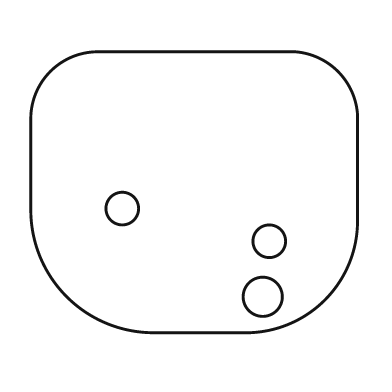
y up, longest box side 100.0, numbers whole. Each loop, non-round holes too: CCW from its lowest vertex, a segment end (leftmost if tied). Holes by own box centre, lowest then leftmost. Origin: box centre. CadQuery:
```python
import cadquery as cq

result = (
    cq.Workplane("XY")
    .moveTo(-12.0, -43.0)
    .lineTo(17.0, -43.0)
    .threePointArc((40.0, -33.0), (50.0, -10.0))
    .lineTo(50.0, 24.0)
    .threePointArc((44.0, 37.0), (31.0, 43.0))
    .lineTo(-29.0, 43.0)
    .threePointArc((-44.0, 37.0), (-50.0, 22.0))
    .lineTo(-50.0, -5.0)
    .threePointArc((-39.0, -32.0), (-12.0, -43.0))
    .close()
    .moveTo(21.0, -32.0)
    .circle(6.0)
    .moveTo(23.0, -15.0)
    .circle(5.0)
    .moveTo(-22.0, -5.0)
    .circle(5.0)
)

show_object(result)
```